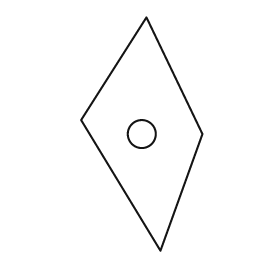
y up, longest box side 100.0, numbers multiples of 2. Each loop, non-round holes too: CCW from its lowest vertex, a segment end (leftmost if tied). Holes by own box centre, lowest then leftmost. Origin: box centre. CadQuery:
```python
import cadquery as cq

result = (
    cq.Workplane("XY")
    .moveTo(8.0, -50.0)
    .lineTo(26.0, 0.0)
    .lineTo(2.0, 50.0)
    .lineTo(-26.0, 6.0)
    .close()
    .moveTo(0.0, 0.0)
    .circle(6.0)
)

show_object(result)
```